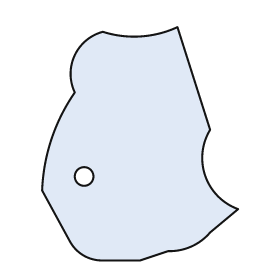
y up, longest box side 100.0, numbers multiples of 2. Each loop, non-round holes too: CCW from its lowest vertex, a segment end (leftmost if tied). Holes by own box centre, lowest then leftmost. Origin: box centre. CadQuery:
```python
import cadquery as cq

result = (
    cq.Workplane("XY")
    .moveTo(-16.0, -50.0)
    .lineTo(0.0, -50.0)
    .lineTo(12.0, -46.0)
    .threePointArc((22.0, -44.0), (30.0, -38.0))
    .lineTo(42.0, -28.0)
    .threePointArc((28.0, -14.0), (30.0, 6.0))
    .lineTo(16.0, 50.0)
    .threePointArc((0.0, 46.0), (-16.0, 48.0))
    .threePointArc((-28.0, 38.0), (-28.0, 22.0))
    .threePointArc((-38.0, 2.0), (-42.0, -20.0))
    .lineTo(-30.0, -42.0)
    .threePointArc((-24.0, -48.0), (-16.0, -50.0))
    .close()
    .moveTo(-24.0, -14.0)
    .circle(4.0)
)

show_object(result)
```